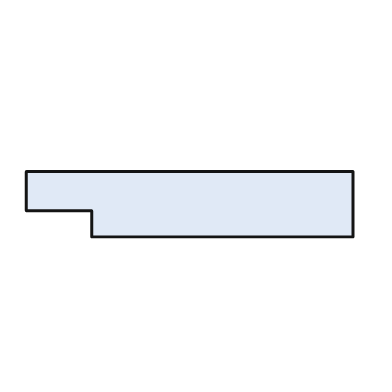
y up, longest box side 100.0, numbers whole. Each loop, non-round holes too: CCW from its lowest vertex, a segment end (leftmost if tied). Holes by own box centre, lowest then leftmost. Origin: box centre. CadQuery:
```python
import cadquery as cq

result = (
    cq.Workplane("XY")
    .moveTo(-30.0, -10.0)
    .lineTo(50.0, -10.0)
    .lineTo(50.0, 10.0)
    .lineTo(-50.0, 10.0)
    .lineTo(-50.0, -2.0)
    .lineTo(-30.0, -2.0)
    .close()
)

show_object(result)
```